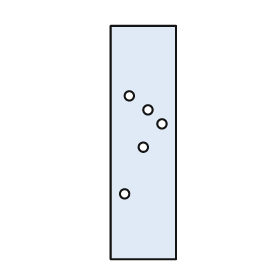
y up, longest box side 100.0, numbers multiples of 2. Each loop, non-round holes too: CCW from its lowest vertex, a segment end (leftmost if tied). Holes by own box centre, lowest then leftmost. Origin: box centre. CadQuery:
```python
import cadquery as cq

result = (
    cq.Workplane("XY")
    .moveTo(-14.0, -50.0)
    .lineTo(14.0, -50.0)
    .lineTo(14.0, 50.0)
    .lineTo(-14.0, 50.0)
    .close()
    .moveTo(-8.0, -22.0)
    .circle(2.0)
    .moveTo(0.0, -2.0)
    .circle(2.0)
    .moveTo(8.0, 8.0)
    .circle(2.0)
    .moveTo(2.0, 14.0)
    .circle(2.0)
    .moveTo(-6.0, 20.0)
    .circle(2.0)
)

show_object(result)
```